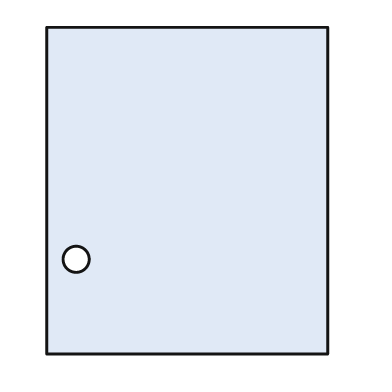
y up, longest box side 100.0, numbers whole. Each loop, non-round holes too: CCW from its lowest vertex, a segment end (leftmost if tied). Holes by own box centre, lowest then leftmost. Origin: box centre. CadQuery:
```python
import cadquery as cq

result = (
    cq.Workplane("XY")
    .moveTo(-43.0, -50.0)
    .lineTo(43.0, -50.0)
    .lineTo(43.0, 50.0)
    .lineTo(-43.0, 50.0)
    .close()
    .moveTo(-34.0, -21.0)
    .circle(4.0)
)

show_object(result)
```